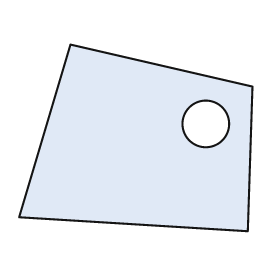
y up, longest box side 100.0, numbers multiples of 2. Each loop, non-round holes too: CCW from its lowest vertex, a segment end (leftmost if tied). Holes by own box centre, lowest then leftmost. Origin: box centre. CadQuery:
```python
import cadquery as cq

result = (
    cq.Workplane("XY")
    .moveTo(48.0, -40.0)
    .lineTo(50.0, 22.0)
    .lineTo(-28.0, 40.0)
    .lineTo(-50.0, -34.0)
    .close()
    .moveTo(30.0, 6.0)
    .circle(10.0)
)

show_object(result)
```